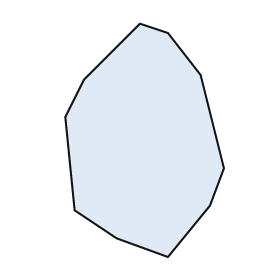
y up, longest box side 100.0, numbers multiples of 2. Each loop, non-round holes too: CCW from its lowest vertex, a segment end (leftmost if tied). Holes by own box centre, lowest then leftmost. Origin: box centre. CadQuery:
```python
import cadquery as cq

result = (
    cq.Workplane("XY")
    .moveTo(10.0, -50.0)
    .lineTo(28.0, -28.0)
    .lineTo(34.0, -12.0)
    .lineTo(24.0, 28.0)
    .lineTo(10.0, 46.0)
    .lineTo(-2.0, 50.0)
    .lineTo(-26.0, 26.0)
    .lineTo(-34.0, 10.0)
    .lineTo(-30.0, -30.0)
    .lineTo(-12.0, -42.0)
    .close()
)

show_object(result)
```